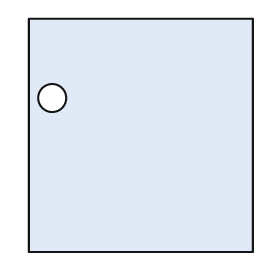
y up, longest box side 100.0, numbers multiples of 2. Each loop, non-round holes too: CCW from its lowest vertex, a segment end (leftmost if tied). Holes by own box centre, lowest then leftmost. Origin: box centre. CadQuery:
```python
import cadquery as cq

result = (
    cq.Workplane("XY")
    .moveTo(-48.0, -50.0)
    .lineTo(48.0, -50.0)
    .lineTo(48.0, 50.0)
    .lineTo(-48.0, 50.0)
    .close()
    .moveTo(-38.0, 16.0)
    .circle(6.0)
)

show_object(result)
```